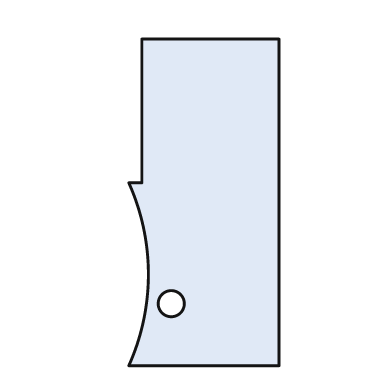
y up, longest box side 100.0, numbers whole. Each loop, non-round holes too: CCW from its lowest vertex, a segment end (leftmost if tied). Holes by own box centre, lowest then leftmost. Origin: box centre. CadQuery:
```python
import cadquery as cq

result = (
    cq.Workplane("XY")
    .moveTo(-23.0, -50.0)
    .lineTo(23.0, -50.0)
    .lineTo(23.0, 50.0)
    .lineTo(-19.0, 50.0)
    .lineTo(-19.0, 6.0)
    .lineTo(-23.0, 6.0)
    .threePointArc((-17.0, -22.0), (-23.0, -50.0))
    .close()
    .moveTo(-10.0, -31.0)
    .circle(4.0)
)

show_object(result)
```